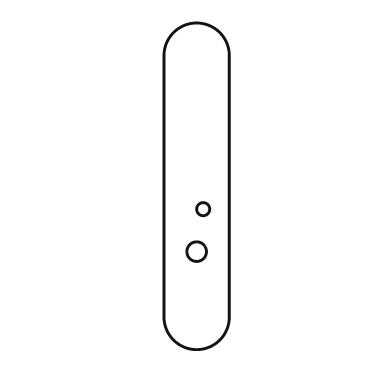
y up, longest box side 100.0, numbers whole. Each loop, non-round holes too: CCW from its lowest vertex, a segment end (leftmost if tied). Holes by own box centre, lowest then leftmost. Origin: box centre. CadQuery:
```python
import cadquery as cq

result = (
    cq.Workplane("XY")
    .moveTo(-10.0, -40.0)
    .threePointArc((0.0, -50.0), (10.0, -40.0))
    .lineTo(10.0, 40.0)
    .threePointArc((0.0, 50.0), (-10.0, 40.0))
    .close()
    .moveTo(0.0, -20.0)
    .circle(3.0)
    .moveTo(2.0, -7.0)
    .circle(2.0)
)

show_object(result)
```